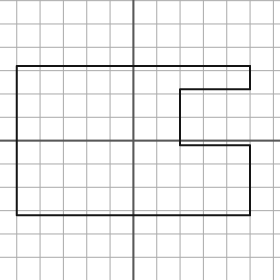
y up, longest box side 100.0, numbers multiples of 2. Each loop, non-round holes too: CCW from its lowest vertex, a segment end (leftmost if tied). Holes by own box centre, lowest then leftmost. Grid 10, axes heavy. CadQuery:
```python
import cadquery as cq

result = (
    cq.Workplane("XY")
    .moveTo(-50.0, -32.0)
    .lineTo(50.0, -32.0)
    .lineTo(50.0, -2.0)
    .lineTo(20.0, -2.0)
    .lineTo(20.0, 22.0)
    .lineTo(50.0, 22.0)
    .lineTo(50.0, 32.0)
    .lineTo(-50.0, 32.0)
    .close()
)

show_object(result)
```